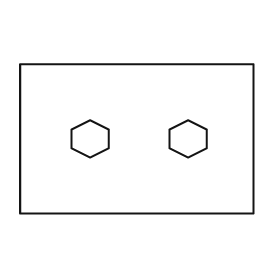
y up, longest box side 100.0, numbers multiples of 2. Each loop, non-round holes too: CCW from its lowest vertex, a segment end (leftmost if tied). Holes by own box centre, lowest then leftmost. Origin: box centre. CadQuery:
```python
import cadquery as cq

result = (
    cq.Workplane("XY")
    .moveTo(-50.0, -32.0)
    .lineTo(50.0, -32.0)
    .lineTo(50.0, 32.0)
    .lineTo(-50.0, 32.0)
    .close()
    .moveTo(-20.0, -8.0)
    .lineTo(-12.0, -4.0)
    .lineTo(-12.0, 4.0)
    .lineTo(-20.0, 8.0)
    .lineTo(-28.0, 4.0)
    .lineTo(-28.0, -4.0)
    .close()
    .moveTo(22.0, -8.0)
    .lineTo(30.0, -4.0)
    .lineTo(30.0, 4.0)
    .lineTo(22.0, 8.0)
    .lineTo(14.0, 4.0)
    .lineTo(14.0, -4.0)
    .close()
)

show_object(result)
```